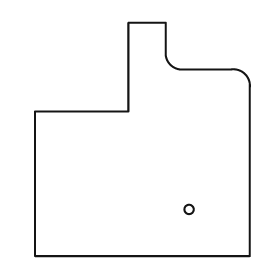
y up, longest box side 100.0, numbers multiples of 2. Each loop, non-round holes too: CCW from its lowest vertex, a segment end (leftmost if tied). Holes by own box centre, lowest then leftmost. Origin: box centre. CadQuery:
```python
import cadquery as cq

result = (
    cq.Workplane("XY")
    .moveTo(-46.0, -50.0)
    .lineTo(46.0, -50.0)
    .lineTo(46.0, 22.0)
    .threePointArc((44.0, 28.0), (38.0, 30.0))
    .lineTo(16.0, 30.0)
    .threePointArc((12.0, 32.0), (10.0, 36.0))
    .lineTo(10.0, 50.0)
    .lineTo(-6.0, 50.0)
    .lineTo(-6.0, 12.0)
    .lineTo(-46.0, 12.0)
    .close()
    .moveTo(20.0, -30.0)
    .circle(2.0)
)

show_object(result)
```